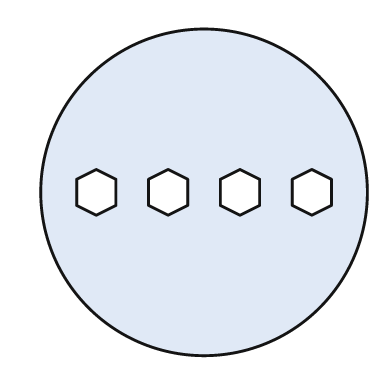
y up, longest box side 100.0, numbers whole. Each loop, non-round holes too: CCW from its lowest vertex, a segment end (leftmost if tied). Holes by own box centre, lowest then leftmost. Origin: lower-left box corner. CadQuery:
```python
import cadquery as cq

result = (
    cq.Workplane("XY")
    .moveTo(50.0, 50.0)
    .circle(50.0)
    .moveTo(17.0, 43.0)
    .lineTo(23.0, 46.0)
    .lineTo(23.0, 54.0)
    .lineTo(17.0, 57.0)
    .lineTo(11.0, 54.0)
    .lineTo(11.0, 46.0)
    .close()
    .moveTo(39.0, 43.0)
    .lineTo(45.0, 46.0)
    .lineTo(45.0, 54.0)
    .lineTo(39.0, 57.0)
    .lineTo(33.0, 54.0)
    .lineTo(33.0, 46.0)
    .close()
    .moveTo(61.0, 43.0)
    .lineTo(67.0, 46.0)
    .lineTo(67.0, 54.0)
    .lineTo(61.0, 57.0)
    .lineTo(55.0, 54.0)
    .lineTo(55.0, 46.0)
    .close()
    .moveTo(83.0, 43.0)
    .lineTo(89.0, 46.0)
    .lineTo(89.0, 54.0)
    .lineTo(83.0, 57.0)
    .lineTo(77.0, 54.0)
    .lineTo(77.0, 46.0)
    .close()
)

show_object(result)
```